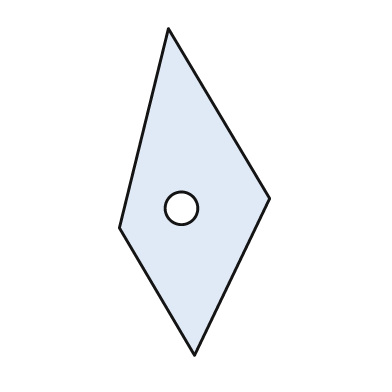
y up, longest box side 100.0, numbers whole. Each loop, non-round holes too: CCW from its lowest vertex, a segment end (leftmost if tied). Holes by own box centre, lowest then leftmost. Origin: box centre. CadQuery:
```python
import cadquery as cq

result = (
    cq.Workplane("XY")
    .moveTo(0.0, -50.0)
    .lineTo(23.0, -2.0)
    .lineTo(-8.0, 50.0)
    .lineTo(-23.0, -11.0)
    .close()
    .moveTo(-4.0, -5.0)
    .circle(5.0)
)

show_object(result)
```